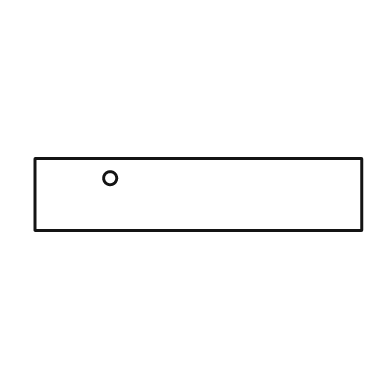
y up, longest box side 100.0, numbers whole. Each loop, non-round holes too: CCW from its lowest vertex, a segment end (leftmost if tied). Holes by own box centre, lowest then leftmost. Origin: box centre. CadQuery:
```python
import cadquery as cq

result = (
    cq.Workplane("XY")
    .moveTo(-50.0, -11.0)
    .lineTo(50.0, -11.0)
    .lineTo(50.0, 11.0)
    .lineTo(-50.0, 11.0)
    .close()
    .moveTo(-27.0, 5.0)
    .circle(2.0)
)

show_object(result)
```